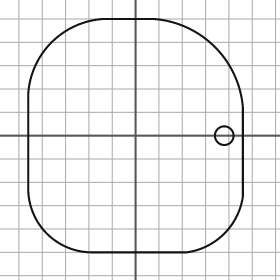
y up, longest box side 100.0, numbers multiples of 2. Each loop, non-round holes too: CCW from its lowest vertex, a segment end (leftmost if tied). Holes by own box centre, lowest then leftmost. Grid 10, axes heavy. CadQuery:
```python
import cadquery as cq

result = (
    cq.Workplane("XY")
    .moveTo(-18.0, -50.0)
    .lineTo(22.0, -50.0)
    .threePointArc((38.0, -42.0), (46.0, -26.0))
    .lineTo(46.0, 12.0)
    .threePointArc((34.0, 38.0), (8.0, 50.0))
    .lineTo(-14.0, 50.0)
    .threePointArc((-36.0, 40.0), (-46.0, 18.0))
    .lineTo(-46.0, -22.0)
    .threePointArc((-38.0, -42.0), (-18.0, -50.0))
    .close()
    .moveTo(38.0, 0.0)
    .circle(4.0)
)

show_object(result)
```